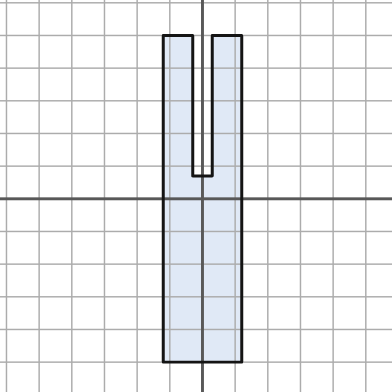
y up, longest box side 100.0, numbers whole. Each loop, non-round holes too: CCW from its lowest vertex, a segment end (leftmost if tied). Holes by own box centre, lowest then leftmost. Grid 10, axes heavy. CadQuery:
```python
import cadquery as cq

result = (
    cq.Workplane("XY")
    .moveTo(-12.0, -50.0)
    .lineTo(12.0, -50.0)
    .lineTo(12.0, 50.0)
    .lineTo(3.0, 50.0)
    .lineTo(3.0, 7.0)
    .lineTo(-3.0, 7.0)
    .lineTo(-3.0, 50.0)
    .lineTo(-12.0, 50.0)
    .close()
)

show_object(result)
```